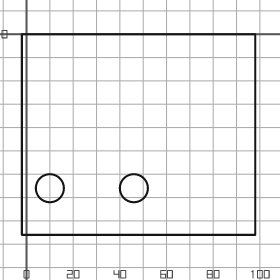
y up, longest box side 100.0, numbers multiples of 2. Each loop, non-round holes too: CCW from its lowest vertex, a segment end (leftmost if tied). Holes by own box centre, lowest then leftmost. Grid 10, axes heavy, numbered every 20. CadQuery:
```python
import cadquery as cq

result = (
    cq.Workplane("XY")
    .moveTo(-2.0, -86.0)
    .lineTo(98.0, -86.0)
    .lineTo(98.0, 0.0)
    .lineTo(-2.0, 0.0)
    .close()
    .moveTo(10.0, -66.0)
    .circle(6.0)
    .moveTo(46.0, -66.0)
    .circle(6.0)
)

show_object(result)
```